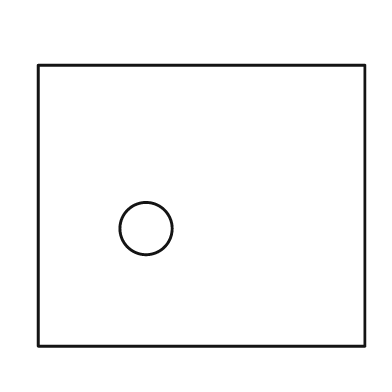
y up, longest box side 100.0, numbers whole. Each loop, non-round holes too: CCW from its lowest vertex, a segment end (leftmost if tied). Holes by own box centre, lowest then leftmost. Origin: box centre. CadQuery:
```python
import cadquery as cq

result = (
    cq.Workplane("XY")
    .moveTo(-50.0, -43.0)
    .lineTo(50.0, -43.0)
    .lineTo(50.0, 43.0)
    .lineTo(-50.0, 43.0)
    .close()
    .moveTo(-17.0, -7.0)
    .circle(8.0)
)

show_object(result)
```